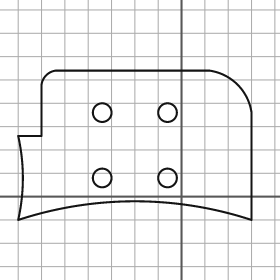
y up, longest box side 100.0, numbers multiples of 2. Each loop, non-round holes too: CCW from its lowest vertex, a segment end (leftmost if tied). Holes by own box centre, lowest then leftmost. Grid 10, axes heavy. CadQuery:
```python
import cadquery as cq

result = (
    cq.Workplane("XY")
    .moveTo(-70.0, -10.0)
    .threePointArc((-20.0, -2.0), (30.0, -10.0))
    .lineTo(30.0, 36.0)
    .threePointArc((24.0, 48.0), (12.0, 54.0))
    .lineTo(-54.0, 54.0)
    .threePointArc((-58.0, 52.0), (-60.0, 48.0))
    .lineTo(-60.0, 26.0)
    .lineTo(-70.0, 26.0)
    .threePointArc((-68.0, 8.0), (-70.0, -10.0))
    .close()
    .moveTo(-34.0, 8.0)
    .circle(4.0)
    .moveTo(-6.0, 8.0)
    .circle(4.0)
    .moveTo(-34.0, 36.0)
    .circle(4.0)
    .moveTo(-6.0, 36.0)
    .circle(4.0)
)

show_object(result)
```